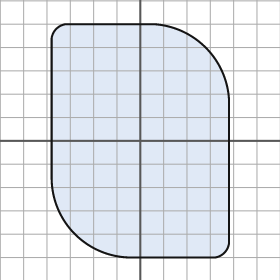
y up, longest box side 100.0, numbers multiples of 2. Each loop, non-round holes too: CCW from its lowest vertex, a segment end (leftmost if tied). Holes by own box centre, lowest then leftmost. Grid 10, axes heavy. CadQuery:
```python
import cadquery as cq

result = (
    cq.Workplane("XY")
    .moveTo(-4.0, -50.0)
    .lineTo(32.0, -50.0)
    .threePointArc((36.0, -48.0), (38.0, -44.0))
    .lineTo(38.0, 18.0)
    .threePointArc((28.0, 40.0), (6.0, 50.0))
    .lineTo(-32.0, 50.0)
    .threePointArc((-36.0, 48.0), (-38.0, 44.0))
    .lineTo(-38.0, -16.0)
    .threePointArc((-28.0, -40.0), (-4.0, -50.0))
    .close()
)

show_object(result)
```